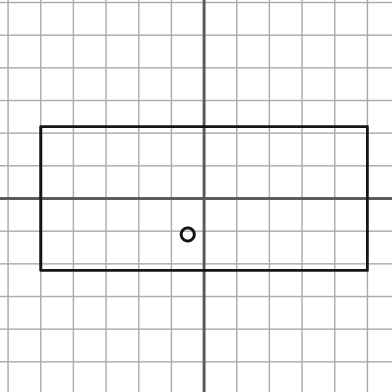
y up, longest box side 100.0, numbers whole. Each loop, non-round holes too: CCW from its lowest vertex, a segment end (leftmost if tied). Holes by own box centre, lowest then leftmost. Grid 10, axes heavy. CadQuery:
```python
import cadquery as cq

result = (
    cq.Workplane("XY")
    .moveTo(-50.0, -22.0)
    .lineTo(50.0, -22.0)
    .lineTo(50.0, 22.0)
    .lineTo(-50.0, 22.0)
    .close()
    .moveTo(-5.0, -11.0)
    .circle(2.0)
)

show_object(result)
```